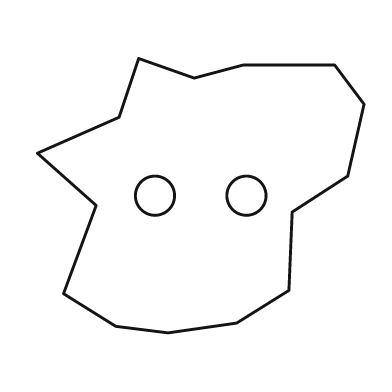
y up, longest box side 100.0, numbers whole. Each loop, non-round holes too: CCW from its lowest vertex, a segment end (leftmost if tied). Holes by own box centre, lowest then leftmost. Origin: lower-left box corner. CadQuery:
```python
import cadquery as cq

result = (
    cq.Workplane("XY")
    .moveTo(40.0, 0.0)
    .lineTo(61.0, 3.0)
    .lineTo(77.0, 13.0)
    .lineTo(78.0, 37.0)
    .lineTo(95.0, 48.0)
    .lineTo(100.0, 70.0)
    .lineTo(91.0, 82.0)
    .lineTo(63.0, 82.0)
    .lineTo(48.0, 78.0)
    .lineTo(31.0, 84.0)
    .lineTo(25.0, 66.0)
    .lineTo(0.0, 55.0)
    .lineTo(18.0, 39.0)
    .lineTo(8.0, 12.0)
    .lineTo(24.0, 2.0)
    .close()
    .moveTo(36.0, 42.0)
    .circle(6.0)
    .moveTo(64.0, 42.0)
    .circle(6.0)
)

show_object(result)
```